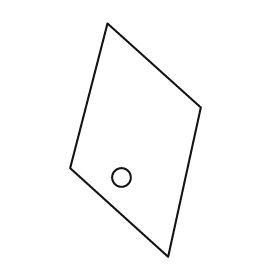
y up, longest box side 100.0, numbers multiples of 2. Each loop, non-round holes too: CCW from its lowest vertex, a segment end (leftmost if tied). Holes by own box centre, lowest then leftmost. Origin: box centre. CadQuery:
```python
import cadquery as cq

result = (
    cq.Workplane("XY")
    .moveTo(14.0, -50.0)
    .lineTo(28.0, 14.0)
    .lineTo(-12.0, 50.0)
    .lineTo(-28.0, -12.0)
    .close()
    .moveTo(-6.0, -16.0)
    .circle(4.0)
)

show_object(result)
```